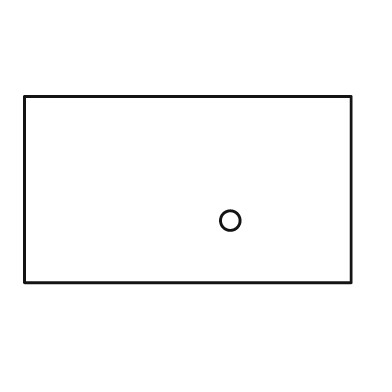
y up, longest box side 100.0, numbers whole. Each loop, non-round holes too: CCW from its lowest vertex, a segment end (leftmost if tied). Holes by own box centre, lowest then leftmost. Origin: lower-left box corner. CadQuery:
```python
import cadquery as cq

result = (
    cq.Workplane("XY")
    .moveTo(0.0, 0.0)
    .lineTo(100.0, 0.0)
    .lineTo(100.0, 57.0)
    .lineTo(0.0, 57.0)
    .close()
    .moveTo(63.0, 19.0)
    .circle(3.0)
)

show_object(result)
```